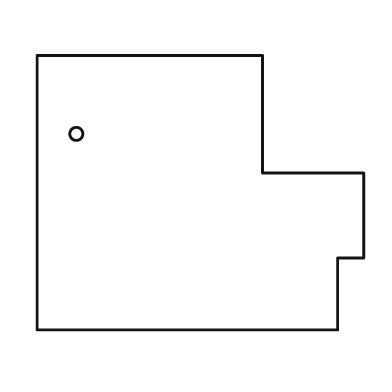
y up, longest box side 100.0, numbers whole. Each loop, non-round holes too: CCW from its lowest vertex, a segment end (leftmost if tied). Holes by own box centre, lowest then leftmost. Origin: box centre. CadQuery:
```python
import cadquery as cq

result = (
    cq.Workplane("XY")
    .moveTo(-50.0, -42.0)
    .lineTo(42.0, -42.0)
    .lineTo(42.0, -20.0)
    .lineTo(50.0, -20.0)
    .lineTo(50.0, 6.0)
    .lineTo(19.0, 6.0)
    .lineTo(19.0, 42.0)
    .lineTo(-50.0, 42.0)
    .close()
    .moveTo(-38.0, 18.0)
    .circle(2.0)
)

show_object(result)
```